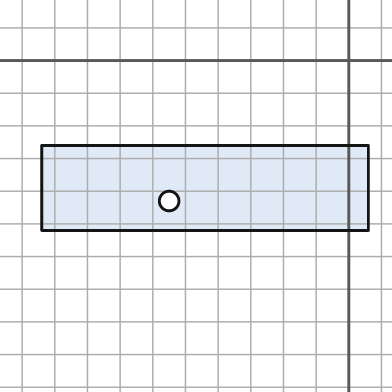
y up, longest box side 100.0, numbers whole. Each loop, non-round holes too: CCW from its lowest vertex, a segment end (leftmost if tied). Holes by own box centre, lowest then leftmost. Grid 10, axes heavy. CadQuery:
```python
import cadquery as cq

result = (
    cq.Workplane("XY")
    .moveTo(-94.0, -52.0)
    .lineTo(6.0, -52.0)
    .lineTo(6.0, -26.0)
    .lineTo(-94.0, -26.0)
    .close()
    .moveTo(-55.0, -43.0)
    .circle(3.0)
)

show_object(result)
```